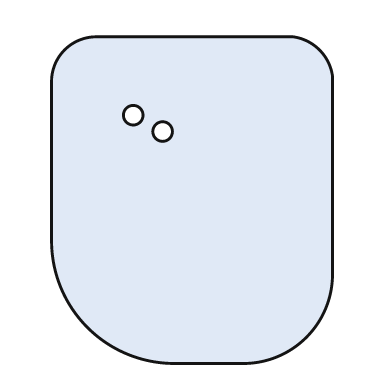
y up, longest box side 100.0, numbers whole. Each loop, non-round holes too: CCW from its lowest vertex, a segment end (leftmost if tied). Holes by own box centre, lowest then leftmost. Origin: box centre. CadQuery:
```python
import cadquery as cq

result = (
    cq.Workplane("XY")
    .moveTo(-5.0, -50.0)
    .lineTo(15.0, -50.0)
    .threePointArc((35.0, -42.0), (43.0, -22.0))
    .lineTo(43.0, 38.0)
    .threePointArc((39.0, 46.0), (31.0, 50.0))
    .lineTo(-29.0, 50.0)
    .threePointArc((-39.0, 46.0), (-43.0, 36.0))
    .lineTo(-43.0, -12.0)
    .threePointArc((-32.0, -39.0), (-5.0, -50.0))
    .close()
    .moveTo(-9.0, 21.0)
    .circle(3.0)
    .moveTo(-18.0, 26.0)
    .circle(3.0)
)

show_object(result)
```